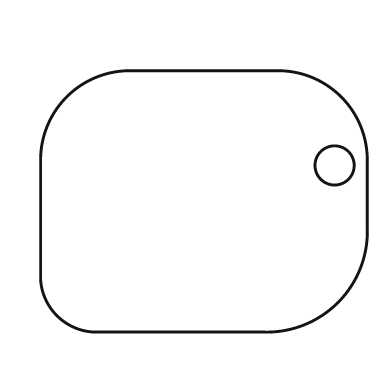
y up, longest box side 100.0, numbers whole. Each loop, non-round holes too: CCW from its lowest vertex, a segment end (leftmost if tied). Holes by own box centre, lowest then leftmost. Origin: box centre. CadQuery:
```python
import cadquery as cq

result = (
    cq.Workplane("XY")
    .moveTo(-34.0, -40.0)
    .lineTo(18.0, -40.0)
    .threePointArc((41.0, -31.0), (50.0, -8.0))
    .lineTo(50.0, 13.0)
    .threePointArc((42.0, 32.0), (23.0, 40.0))
    .lineTo(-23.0, 40.0)
    .threePointArc((-42.0, 32.0), (-50.0, 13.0))
    .lineTo(-50.0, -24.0)
    .threePointArc((-45.0, -35.0), (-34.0, -40.0))
    .close()
    .moveTo(40.0, 11.0)
    .circle(6.0)
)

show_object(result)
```